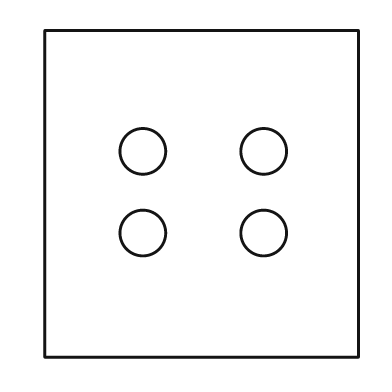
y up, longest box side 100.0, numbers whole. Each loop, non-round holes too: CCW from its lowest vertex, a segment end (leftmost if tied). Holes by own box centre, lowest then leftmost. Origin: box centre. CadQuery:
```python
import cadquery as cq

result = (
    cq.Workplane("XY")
    .moveTo(-48.0, -50.0)
    .lineTo(48.0, -50.0)
    .lineTo(48.0, 50.0)
    .lineTo(-48.0, 50.0)
    .close()
    .moveTo(-18.0, -12.0)
    .circle(7.0)
    .moveTo(19.0, -12.0)
    .circle(7.0)
    .moveTo(-18.0, 13.0)
    .circle(7.0)
    .moveTo(19.0, 13.0)
    .circle(7.0)
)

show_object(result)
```